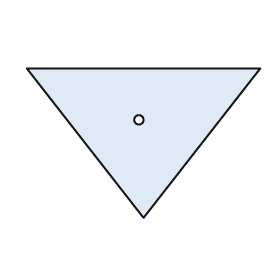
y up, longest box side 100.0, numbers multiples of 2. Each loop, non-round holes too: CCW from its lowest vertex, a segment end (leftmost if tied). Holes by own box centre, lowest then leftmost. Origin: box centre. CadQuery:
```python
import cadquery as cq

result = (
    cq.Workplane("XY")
    .moveTo(0.0, -32.0)
    .lineTo(50.0, 32.0)
    .lineTo(-50.0, 32.0)
    .close()
    .moveTo(-2.0, 10.0)
    .circle(2.0)
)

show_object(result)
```